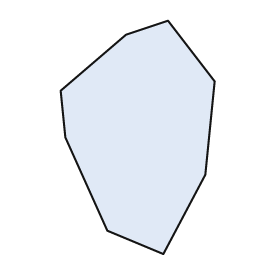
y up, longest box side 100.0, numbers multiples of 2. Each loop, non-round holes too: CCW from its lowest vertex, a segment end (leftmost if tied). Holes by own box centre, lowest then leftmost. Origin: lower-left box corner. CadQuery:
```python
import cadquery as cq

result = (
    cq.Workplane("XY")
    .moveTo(44.0, 0.0)
    .lineTo(62.0, 34.0)
    .lineTo(66.0, 74.0)
    .lineTo(46.0, 100.0)
    .lineTo(28.0, 94.0)
    .lineTo(0.0, 70.0)
    .lineTo(2.0, 50.0)
    .lineTo(20.0, 10.0)
    .close()
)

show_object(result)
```